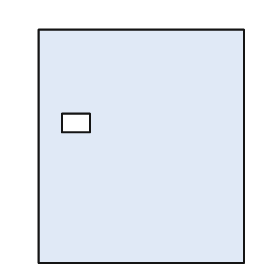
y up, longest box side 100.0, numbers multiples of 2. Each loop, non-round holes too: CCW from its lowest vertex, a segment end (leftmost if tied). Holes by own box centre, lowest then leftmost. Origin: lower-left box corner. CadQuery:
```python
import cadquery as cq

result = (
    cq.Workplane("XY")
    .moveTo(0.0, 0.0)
    .lineTo(88.0, 0.0)
    .lineTo(88.0, 100.0)
    .lineTo(0.0, 100.0)
    .close()
    .moveTo(10.0, 56.0)
    .lineTo(22.0, 56.0)
    .lineTo(22.0, 64.0)
    .lineTo(10.0, 64.0)
    .close()
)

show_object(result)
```